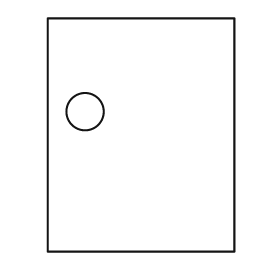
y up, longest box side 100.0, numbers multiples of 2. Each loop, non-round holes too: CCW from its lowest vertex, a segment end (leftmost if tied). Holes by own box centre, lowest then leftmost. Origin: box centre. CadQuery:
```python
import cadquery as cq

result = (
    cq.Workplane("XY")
    .moveTo(-40.0, -50.0)
    .lineTo(40.0, -50.0)
    .lineTo(40.0, 50.0)
    .lineTo(-40.0, 50.0)
    .close()
    .moveTo(-24.0, 10.0)
    .circle(8.0)
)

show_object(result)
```